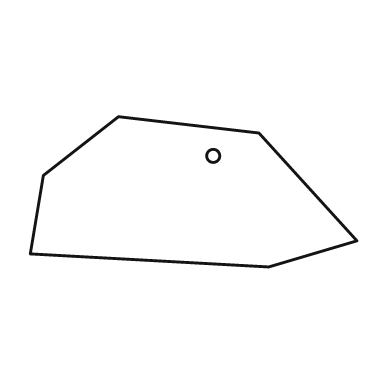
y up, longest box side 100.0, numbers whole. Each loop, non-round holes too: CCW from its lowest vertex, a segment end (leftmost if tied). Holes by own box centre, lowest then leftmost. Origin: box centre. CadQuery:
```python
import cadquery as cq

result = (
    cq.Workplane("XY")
    .moveTo(23.0, -23.0)
    .lineTo(50.0, -15.0)
    .lineTo(20.0, 18.0)
    .lineTo(-23.0, 23.0)
    .lineTo(-46.0, 5.0)
    .lineTo(-50.0, -19.0)
    .close()
    .moveTo(6.0, 11.0)
    .circle(2.0)
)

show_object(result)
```